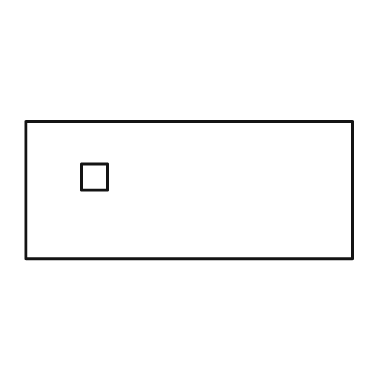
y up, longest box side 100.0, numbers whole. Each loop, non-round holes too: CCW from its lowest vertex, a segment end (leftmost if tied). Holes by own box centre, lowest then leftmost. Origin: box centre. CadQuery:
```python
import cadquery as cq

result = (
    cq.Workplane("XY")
    .moveTo(-50.0, -21.0)
    .lineTo(50.0, -21.0)
    .lineTo(50.0, 21.0)
    .lineTo(-50.0, 21.0)
    .close()
    .moveTo(-33.0, 0.0)
    .lineTo(-25.0, 0.0)
    .lineTo(-25.0, 8.0)
    .lineTo(-33.0, 8.0)
    .close()
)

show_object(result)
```